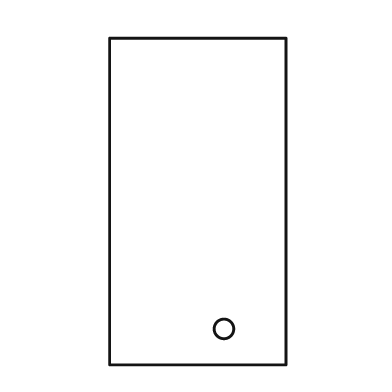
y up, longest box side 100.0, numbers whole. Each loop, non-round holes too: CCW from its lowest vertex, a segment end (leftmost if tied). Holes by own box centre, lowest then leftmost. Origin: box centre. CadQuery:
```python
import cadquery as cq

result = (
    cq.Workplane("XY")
    .moveTo(-27.0, -50.0)
    .lineTo(27.0, -50.0)
    .lineTo(27.0, 50.0)
    .lineTo(-27.0, 50.0)
    .close()
    .moveTo(8.0, -39.0)
    .circle(3.0)
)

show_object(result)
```